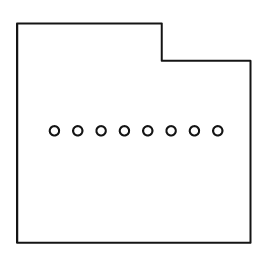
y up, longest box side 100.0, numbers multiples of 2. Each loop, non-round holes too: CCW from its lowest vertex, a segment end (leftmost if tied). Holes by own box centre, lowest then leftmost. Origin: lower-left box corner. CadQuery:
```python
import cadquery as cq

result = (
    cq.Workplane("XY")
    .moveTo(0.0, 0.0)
    .lineTo(100.0, 0.0)
    .lineTo(100.0, 78.0)
    .lineTo(62.0, 78.0)
    .lineTo(62.0, 94.0)
    .lineTo(0.0, 94.0)
    .close()
    .moveTo(16.0, 48.0)
    .circle(2.0)
    .moveTo(26.0, 48.0)
    .circle(2.0)
    .moveTo(36.0, 48.0)
    .circle(2.0)
    .moveTo(46.0, 48.0)
    .circle(2.0)
    .moveTo(56.0, 48.0)
    .circle(2.0)
    .moveTo(66.0, 48.0)
    .circle(2.0)
    .moveTo(76.0, 48.0)
    .circle(2.0)
    .moveTo(86.0, 48.0)
    .circle(2.0)
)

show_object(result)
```